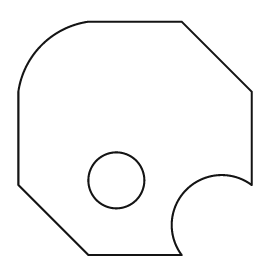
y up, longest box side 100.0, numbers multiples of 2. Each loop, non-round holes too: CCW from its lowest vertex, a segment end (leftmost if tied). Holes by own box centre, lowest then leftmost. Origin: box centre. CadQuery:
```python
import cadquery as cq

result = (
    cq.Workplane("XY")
    .moveTo(-20.0, -50.0)
    .lineTo(20.0, -50.0)
    .threePointArc((22.0, -22.0), (50.0, -20.0))
    .lineTo(50.0, 20.0)
    .lineTo(20.0, 50.0)
    .lineTo(-20.0, 50.0)
    .threePointArc((-40.0, 40.0), (-50.0, 20.0))
    .lineTo(-50.0, -20.0)
    .close()
    .moveTo(-8.0, -18.0)
    .circle(12.0)
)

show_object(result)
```